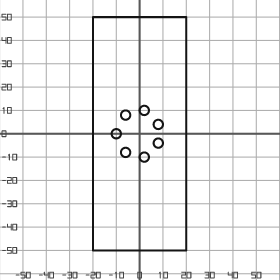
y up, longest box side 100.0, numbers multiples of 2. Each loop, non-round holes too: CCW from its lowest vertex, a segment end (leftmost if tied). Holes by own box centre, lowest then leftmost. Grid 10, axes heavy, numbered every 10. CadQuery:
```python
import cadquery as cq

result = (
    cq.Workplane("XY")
    .moveTo(-20.0, -50.0)
    .lineTo(20.0, -50.0)
    .lineTo(20.0, 50.0)
    .lineTo(-20.0, 50.0)
    .close()
    .moveTo(2.0, -10.0)
    .circle(2.0)
    .moveTo(-6.0, -8.0)
    .circle(2.0)
    .moveTo(8.0, -4.0)
    .circle(2.0)
    .moveTo(-10.0, 0.0)
    .circle(2.0)
    .moveTo(8.0, 4.0)
    .circle(2.0)
    .moveTo(-6.0, 8.0)
    .circle(2.0)
    .moveTo(2.0, 10.0)
    .circle(2.0)
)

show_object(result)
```